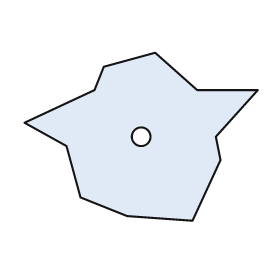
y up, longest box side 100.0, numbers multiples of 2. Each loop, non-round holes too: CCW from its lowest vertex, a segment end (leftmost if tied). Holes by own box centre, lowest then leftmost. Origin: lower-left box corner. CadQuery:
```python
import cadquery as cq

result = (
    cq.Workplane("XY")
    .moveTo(72.0, 0.0)
    .lineTo(84.0, 26.0)
    .lineTo(82.0, 36.0)
    .lineTo(100.0, 56.0)
    .lineTo(74.0, 56.0)
    .lineTo(56.0, 72.0)
    .lineTo(34.0, 66.0)
    .lineTo(30.0, 56.0)
    .lineTo(0.0, 42.0)
    .lineTo(18.0, 32.0)
    .lineTo(24.0, 10.0)
    .lineTo(44.0, 2.0)
    .close()
    .moveTo(50.0, 36.0)
    .circle(4.0)
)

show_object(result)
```